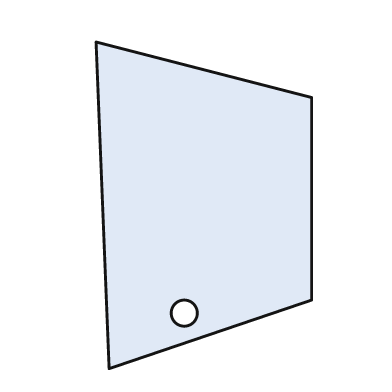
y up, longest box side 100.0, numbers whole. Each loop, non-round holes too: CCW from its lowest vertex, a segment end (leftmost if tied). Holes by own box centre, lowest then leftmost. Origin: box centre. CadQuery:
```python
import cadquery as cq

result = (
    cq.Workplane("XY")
    .moveTo(-29.0, -50.0)
    .lineTo(33.0, -29.0)
    .lineTo(33.0, 33.0)
    .lineTo(-33.0, 50.0)
    .close()
    .moveTo(-6.0, -33.0)
    .circle(4.0)
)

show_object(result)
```